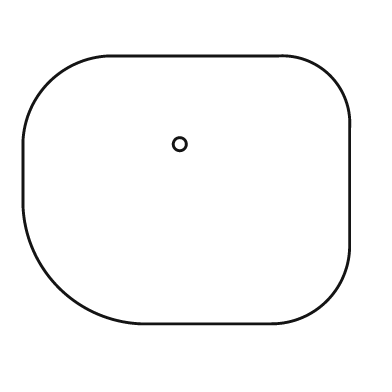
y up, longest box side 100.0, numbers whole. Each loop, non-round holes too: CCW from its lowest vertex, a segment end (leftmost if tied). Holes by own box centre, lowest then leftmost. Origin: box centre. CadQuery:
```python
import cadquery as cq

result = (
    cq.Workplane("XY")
    .moveTo(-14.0, -41.0)
    .lineTo(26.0, -41.0)
    .threePointArc((43.0, -34.0), (50.0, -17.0))
    .lineTo(50.0, 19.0)
    .threePointArc((44.0, 35.0), (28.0, 41.0))
    .lineTo(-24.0, 41.0)
    .threePointArc((-42.0, 33.0), (-50.0, 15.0))
    .lineTo(-50.0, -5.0)
    .threePointArc((-39.0, -30.0), (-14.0, -41.0))
    .close()
    .moveTo(-2.0, 14.0)
    .circle(2.0)
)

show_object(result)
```